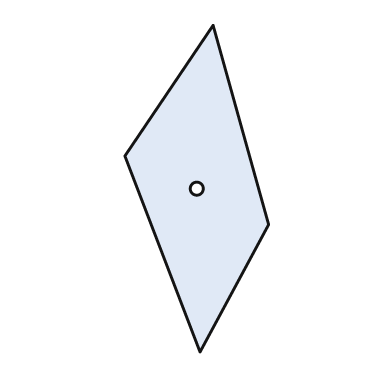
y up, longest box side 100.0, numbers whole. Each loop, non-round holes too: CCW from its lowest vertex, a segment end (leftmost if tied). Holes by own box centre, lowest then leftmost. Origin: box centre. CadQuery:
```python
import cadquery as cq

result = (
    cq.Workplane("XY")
    .moveTo(1.0, -50.0)
    .lineTo(22.0, -11.0)
    .lineTo(5.0, 50.0)
    .lineTo(-22.0, 10.0)
    .close()
    .moveTo(0.0, 0.0)
    .circle(2.0)
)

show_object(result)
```